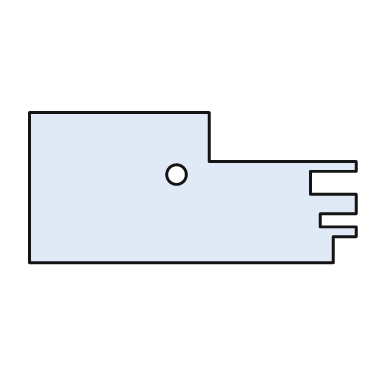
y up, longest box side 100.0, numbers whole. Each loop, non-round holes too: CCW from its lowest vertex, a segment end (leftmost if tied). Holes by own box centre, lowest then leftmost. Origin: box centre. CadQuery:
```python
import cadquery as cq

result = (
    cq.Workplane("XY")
    .moveTo(-50.0, -23.0)
    .lineTo(43.0, -23.0)
    .lineTo(43.0, -15.0)
    .lineTo(50.0, -15.0)
    .lineTo(50.0, -12.0)
    .lineTo(39.0, -12.0)
    .lineTo(39.0, -8.0)
    .lineTo(50.0, -8.0)
    .lineTo(50.0, -2.0)
    .lineTo(36.0, -2.0)
    .lineTo(36.0, 5.0)
    .lineTo(50.0, 5.0)
    .lineTo(50.0, 8.0)
    .lineTo(5.0, 8.0)
    .lineTo(5.0, 23.0)
    .lineTo(-50.0, 23.0)
    .close()
    .moveTo(-5.0, 4.0)
    .circle(3.0)
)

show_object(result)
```